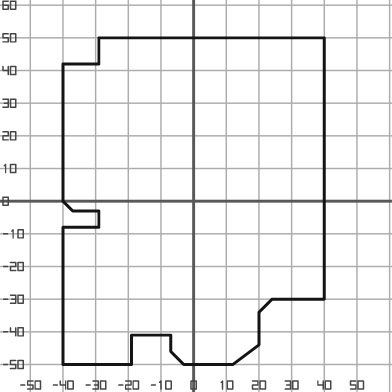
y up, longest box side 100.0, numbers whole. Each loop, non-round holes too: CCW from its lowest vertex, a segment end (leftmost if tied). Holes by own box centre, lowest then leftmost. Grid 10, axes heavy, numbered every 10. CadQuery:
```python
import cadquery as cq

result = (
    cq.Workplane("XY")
    .moveTo(-40.0, -50.0)
    .lineTo(-19.0, -50.0)
    .lineTo(-19.0, -41.0)
    .lineTo(-7.0, -41.0)
    .lineTo(-7.0, -46.0)
    .lineTo(-3.0, -50.0)
    .lineTo(12.0, -50.0)
    .lineTo(20.0, -44.0)
    .lineTo(20.0, -34.0)
    .lineTo(24.0, -30.0)
    .lineTo(40.0, -30.0)
    .lineTo(40.0, 50.0)
    .lineTo(-29.0, 50.0)
    .lineTo(-29.0, 42.0)
    .lineTo(-40.0, 42.0)
    .lineTo(-40.0, 0.0)
    .lineTo(-37.0, -3.0)
    .lineTo(-29.0, -3.0)
    .lineTo(-29.0, -8.0)
    .lineTo(-40.0, -8.0)
    .close()
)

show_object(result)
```